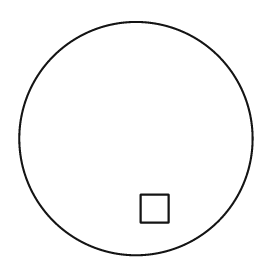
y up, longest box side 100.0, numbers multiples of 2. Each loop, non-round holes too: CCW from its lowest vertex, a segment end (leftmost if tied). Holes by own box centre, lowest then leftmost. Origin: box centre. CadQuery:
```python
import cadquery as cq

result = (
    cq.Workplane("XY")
    .moveTo(0.0, 0.0)
    .circle(50.0)
    .moveTo(2.0, -36.0)
    .lineTo(14.0, -36.0)
    .lineTo(14.0, -24.0)
    .lineTo(2.0, -24.0)
    .close()
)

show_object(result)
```